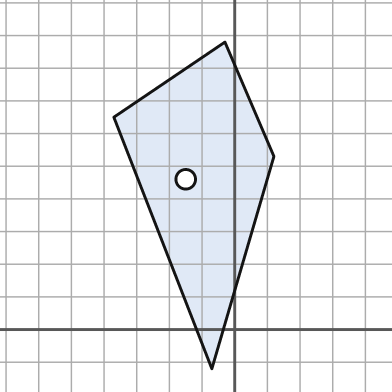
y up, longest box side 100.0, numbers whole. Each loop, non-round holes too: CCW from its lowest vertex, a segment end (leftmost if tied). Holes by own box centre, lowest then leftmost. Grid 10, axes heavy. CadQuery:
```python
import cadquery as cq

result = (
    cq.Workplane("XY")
    .moveTo(-7.0, -12.0)
    .lineTo(12.0, 53.0)
    .lineTo(-3.0, 88.0)
    .lineTo(-37.0, 65.0)
    .close()
    .moveTo(-15.0, 46.0)
    .circle(3.0)
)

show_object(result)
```